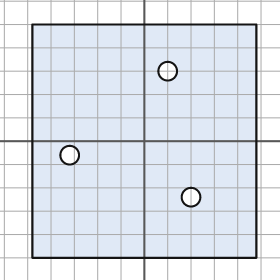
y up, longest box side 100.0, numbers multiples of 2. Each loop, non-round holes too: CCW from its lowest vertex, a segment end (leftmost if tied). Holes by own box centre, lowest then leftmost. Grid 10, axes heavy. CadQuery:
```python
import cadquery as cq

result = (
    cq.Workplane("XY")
    .moveTo(-48.0, -50.0)
    .lineTo(48.0, -50.0)
    .lineTo(48.0, 50.0)
    .lineTo(-48.0, 50.0)
    .close()
    .moveTo(20.0, -24.0)
    .circle(4.0)
    .moveTo(-32.0, -6.0)
    .circle(4.0)
    .moveTo(10.0, 30.0)
    .circle(4.0)
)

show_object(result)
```